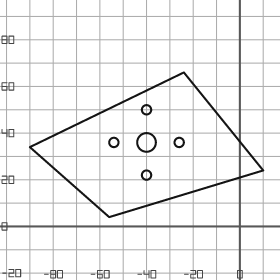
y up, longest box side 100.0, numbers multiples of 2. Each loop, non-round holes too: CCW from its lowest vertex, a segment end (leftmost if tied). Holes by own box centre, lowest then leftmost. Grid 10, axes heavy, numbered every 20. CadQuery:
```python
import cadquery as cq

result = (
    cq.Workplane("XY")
    .moveTo(-56.0, 4.0)
    .lineTo(10.0, 24.0)
    .lineTo(-24.0, 66.0)
    .lineTo(-90.0, 34.0)
    .close()
    .moveTo(-40.0, 22.0)
    .circle(2.0)
    .moveTo(-54.0, 36.0)
    .circle(2.0)
    .moveTo(-40.0, 36.0)
    .circle(4.0)
    .moveTo(-26.0, 36.0)
    .circle(2.0)
    .moveTo(-40.0, 50.0)
    .circle(2.0)
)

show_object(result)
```